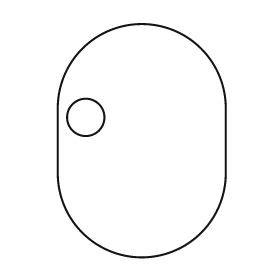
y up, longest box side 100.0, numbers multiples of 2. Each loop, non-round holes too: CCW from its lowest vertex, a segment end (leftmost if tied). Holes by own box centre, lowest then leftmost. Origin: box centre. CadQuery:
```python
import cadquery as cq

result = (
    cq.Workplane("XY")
    .moveTo(-36.0, -14.0)
    .threePointArc((0.0, -50.0), (36.0, -14.0))
    .lineTo(36.0, 14.0)
    .threePointArc((0.0, 50.0), (-36.0, 14.0))
    .close()
    .moveTo(-24.0, 10.0)
    .circle(8.0)
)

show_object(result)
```